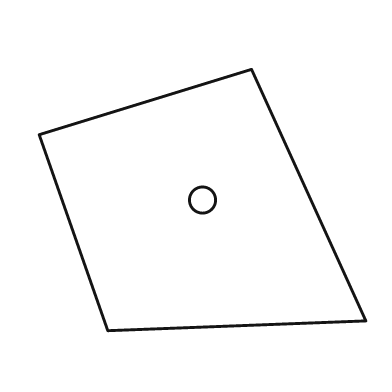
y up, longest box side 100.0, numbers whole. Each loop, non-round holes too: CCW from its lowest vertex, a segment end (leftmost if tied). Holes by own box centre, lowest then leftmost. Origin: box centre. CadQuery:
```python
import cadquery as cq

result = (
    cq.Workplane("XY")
    .moveTo(-29.0, -40.0)
    .lineTo(50.0, -37.0)
    .lineTo(15.0, 40.0)
    .lineTo(-50.0, 20.0)
    .close()
    .moveTo(0.0, 0.0)
    .circle(4.0)
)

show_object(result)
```